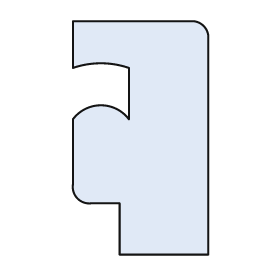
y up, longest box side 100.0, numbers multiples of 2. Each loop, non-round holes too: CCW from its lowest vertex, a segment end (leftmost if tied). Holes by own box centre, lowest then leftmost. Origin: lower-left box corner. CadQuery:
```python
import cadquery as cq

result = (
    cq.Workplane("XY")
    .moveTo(20.0, 0.0)
    .lineTo(58.0, 0.0)
    .lineTo(58.0, 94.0)
    .threePointArc((56.0, 98.0), (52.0, 100.0))
    .lineTo(0.0, 100.0)
    .lineTo(0.0, 80.0)
    .threePointArc((12.0, 82.0), (24.0, 80.0))
    .lineTo(24.0, 58.0)
    .threePointArc((12.0, 64.0), (0.0, 58.0))
    .lineTo(0.0, 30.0)
    .threePointArc((2.0, 24.0), (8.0, 22.0))
    .lineTo(20.0, 22.0)
    .close()
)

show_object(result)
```